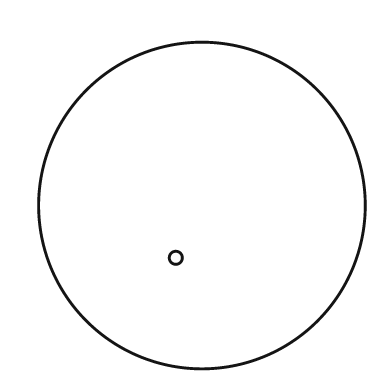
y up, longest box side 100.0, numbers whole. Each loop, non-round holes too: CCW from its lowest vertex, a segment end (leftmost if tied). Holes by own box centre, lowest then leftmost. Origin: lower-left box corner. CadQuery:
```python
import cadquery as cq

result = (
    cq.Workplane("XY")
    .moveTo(50.0, 50.0)
    .circle(50.0)
    .moveTo(42.0, 34.0)
    .circle(2.0)
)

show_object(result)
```